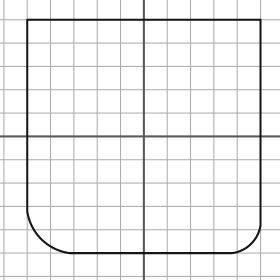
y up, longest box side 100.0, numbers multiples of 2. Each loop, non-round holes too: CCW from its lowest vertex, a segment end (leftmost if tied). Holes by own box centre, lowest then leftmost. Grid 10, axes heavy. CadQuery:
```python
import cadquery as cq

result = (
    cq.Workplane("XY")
    .moveTo(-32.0, -50.0)
    .lineTo(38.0, -50.0)
    .threePointArc((46.0, -46.0), (50.0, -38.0))
    .lineTo(50.0, 50.0)
    .lineTo(-50.0, 50.0)
    .lineTo(-50.0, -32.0)
    .threePointArc((-44.0, -44.0), (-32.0, -50.0))
    .close()
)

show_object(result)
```